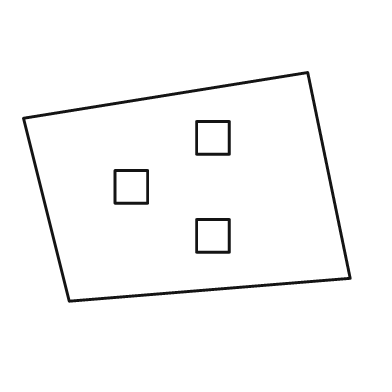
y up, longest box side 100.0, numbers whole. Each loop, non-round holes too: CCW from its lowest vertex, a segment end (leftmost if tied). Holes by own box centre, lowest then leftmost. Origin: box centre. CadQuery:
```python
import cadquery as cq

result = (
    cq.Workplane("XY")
    .moveTo(-36.0, -35.0)
    .lineTo(50.0, -28.0)
    .lineTo(37.0, 35.0)
    .lineTo(-50.0, 21.0)
    .close()
    .moveTo(3.0, -20.0)
    .lineTo(13.0, -20.0)
    .lineTo(13.0, -10.0)
    .lineTo(3.0, -10.0)
    .close()
    .moveTo(-22.0, -5.0)
    .lineTo(-12.0, -5.0)
    .lineTo(-12.0, 5.0)
    .lineTo(-22.0, 5.0)
    .close()
    .moveTo(3.0, 10.0)
    .lineTo(13.0, 10.0)
    .lineTo(13.0, 20.0)
    .lineTo(3.0, 20.0)
    .close()
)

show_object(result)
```